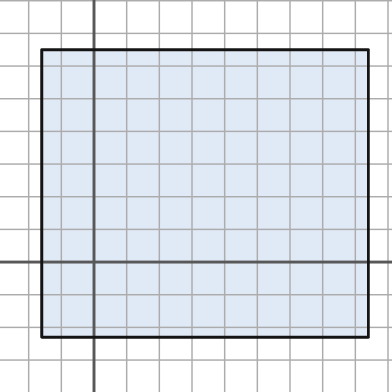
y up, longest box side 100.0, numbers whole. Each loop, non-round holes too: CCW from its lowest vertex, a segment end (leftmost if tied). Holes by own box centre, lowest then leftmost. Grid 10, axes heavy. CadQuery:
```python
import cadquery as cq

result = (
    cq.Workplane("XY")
    .moveTo(-16.0, -23.0)
    .lineTo(84.0, -23.0)
    .lineTo(84.0, 65.0)
    .lineTo(-16.0, 65.0)
    .close()
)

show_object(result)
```